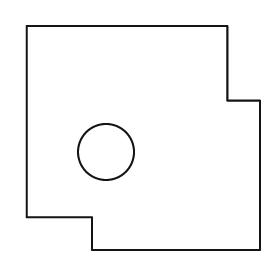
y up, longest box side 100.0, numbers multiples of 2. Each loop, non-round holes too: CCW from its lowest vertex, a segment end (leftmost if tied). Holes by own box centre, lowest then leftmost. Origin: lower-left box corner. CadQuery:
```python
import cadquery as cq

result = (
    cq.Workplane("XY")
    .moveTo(28.0, 0.0)
    .lineTo(100.0, 0.0)
    .lineTo(100.0, 64.0)
    .lineTo(86.0, 64.0)
    .lineTo(86.0, 96.0)
    .lineTo(0.0, 96.0)
    .lineTo(0.0, 14.0)
    .lineTo(28.0, 14.0)
    .close()
    .moveTo(34.0, 42.0)
    .circle(12.0)
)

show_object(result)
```